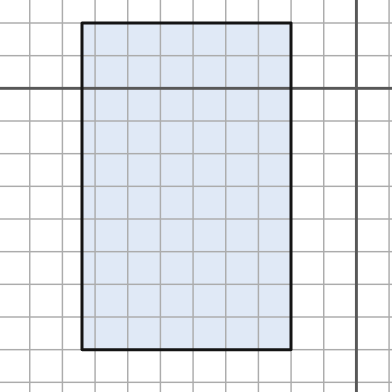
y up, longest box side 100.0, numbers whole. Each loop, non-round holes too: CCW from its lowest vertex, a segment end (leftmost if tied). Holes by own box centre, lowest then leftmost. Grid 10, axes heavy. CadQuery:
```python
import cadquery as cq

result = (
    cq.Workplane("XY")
    .moveTo(-84.0, -80.0)
    .lineTo(-20.0, -80.0)
    .lineTo(-20.0, 20.0)
    .lineTo(-84.0, 20.0)
    .close()
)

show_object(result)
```